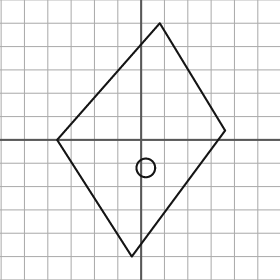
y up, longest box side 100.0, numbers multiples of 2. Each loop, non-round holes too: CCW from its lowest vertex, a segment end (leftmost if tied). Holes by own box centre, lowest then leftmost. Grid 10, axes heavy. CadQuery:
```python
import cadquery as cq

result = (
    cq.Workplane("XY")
    .moveTo(-4.0, -50.0)
    .lineTo(36.0, 4.0)
    .lineTo(8.0, 50.0)
    .lineTo(-36.0, 0.0)
    .close()
    .moveTo(2.0, -12.0)
    .circle(4.0)
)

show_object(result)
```